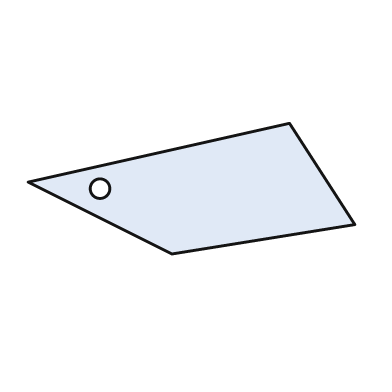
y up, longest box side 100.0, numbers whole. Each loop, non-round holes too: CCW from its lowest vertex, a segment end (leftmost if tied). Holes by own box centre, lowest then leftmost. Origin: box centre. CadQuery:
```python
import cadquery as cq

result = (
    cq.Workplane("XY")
    .moveTo(-6.0, -20.0)
    .lineTo(50.0, -11.0)
    .lineTo(30.0, 20.0)
    .lineTo(-50.0, 2.0)
    .close()
    .moveTo(-28.0, 0.0)
    .circle(3.0)
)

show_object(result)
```